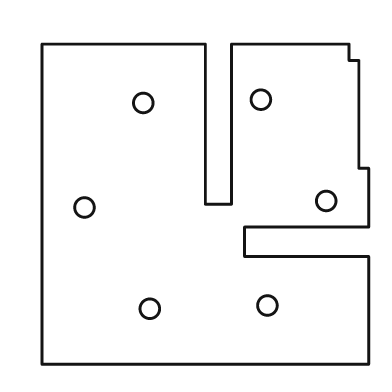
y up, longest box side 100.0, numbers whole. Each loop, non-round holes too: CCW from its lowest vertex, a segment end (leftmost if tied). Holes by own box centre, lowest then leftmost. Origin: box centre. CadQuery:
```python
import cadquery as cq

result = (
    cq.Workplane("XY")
    .moveTo(-50.0, -49.0)
    .lineTo(50.0, -49.0)
    .lineTo(50.0, -16.0)
    .lineTo(12.0, -16.0)
    .lineTo(12.0, -7.0)
    .lineTo(50.0, -7.0)
    .lineTo(50.0, 11.0)
    .lineTo(47.0, 11.0)
    .lineTo(47.0, 44.0)
    .lineTo(44.0, 44.0)
    .lineTo(44.0, 49.0)
    .lineTo(8.0, 49.0)
    .lineTo(8.0, 0.0)
    .lineTo(0.0, 0.0)
    .lineTo(0.0, 49.0)
    .lineTo(-50.0, 49.0)
    .close()
    .moveTo(-17.0, -32.0)
    .circle(3.0)
    .moveTo(19.0, -31.0)
    .circle(3.0)
    .moveTo(-37.0, -1.0)
    .circle(3.0)
    .moveTo(37.0, 1.0)
    .circle(3.0)
    .moveTo(-19.0, 31.0)
    .circle(3.0)
    .moveTo(17.0, 32.0)
    .circle(3.0)
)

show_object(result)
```